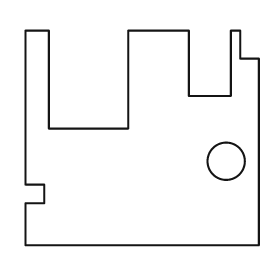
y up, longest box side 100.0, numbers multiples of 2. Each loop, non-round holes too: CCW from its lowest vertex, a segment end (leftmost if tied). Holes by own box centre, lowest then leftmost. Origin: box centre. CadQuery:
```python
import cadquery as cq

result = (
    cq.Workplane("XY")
    .moveTo(-50.0, -46.0)
    .lineTo(50.0, -46.0)
    .lineTo(50.0, 34.0)
    .lineTo(42.0, 34.0)
    .lineTo(42.0, 46.0)
    .lineTo(38.0, 46.0)
    .lineTo(38.0, 18.0)
    .lineTo(20.0, 18.0)
    .lineTo(20.0, 46.0)
    .lineTo(-6.0, 46.0)
    .lineTo(-6.0, 4.0)
    .lineTo(-40.0, 4.0)
    .lineTo(-40.0, 46.0)
    .lineTo(-50.0, 46.0)
    .lineTo(-50.0, -20.0)
    .lineTo(-42.0, -20.0)
    .lineTo(-42.0, -28.0)
    .lineTo(-50.0, -28.0)
    .close()
    .moveTo(36.0, -10.0)
    .circle(8.0)
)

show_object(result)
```